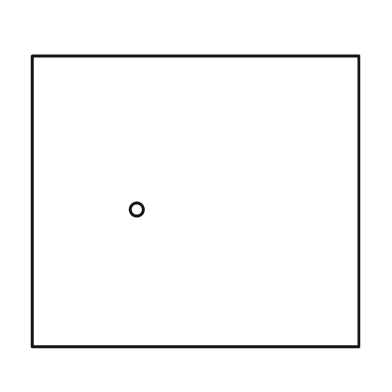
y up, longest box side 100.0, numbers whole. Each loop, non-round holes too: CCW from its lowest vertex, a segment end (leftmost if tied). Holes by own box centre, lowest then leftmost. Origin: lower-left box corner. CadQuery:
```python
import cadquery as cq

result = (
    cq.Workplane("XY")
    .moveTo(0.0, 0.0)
    .lineTo(100.0, 0.0)
    .lineTo(100.0, 89.0)
    .lineTo(0.0, 89.0)
    .close()
    .moveTo(32.0, 42.0)
    .circle(2.0)
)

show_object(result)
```